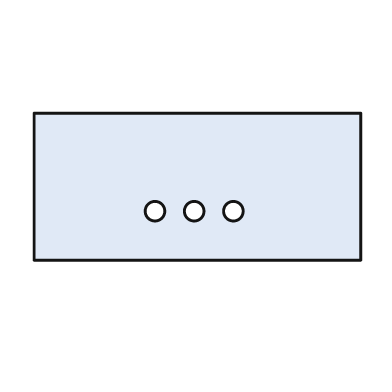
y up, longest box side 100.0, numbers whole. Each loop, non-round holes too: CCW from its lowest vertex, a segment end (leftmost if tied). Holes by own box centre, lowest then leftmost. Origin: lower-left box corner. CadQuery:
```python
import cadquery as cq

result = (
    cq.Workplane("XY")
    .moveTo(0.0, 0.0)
    .lineTo(100.0, 0.0)
    .lineTo(100.0, 45.0)
    .lineTo(0.0, 45.0)
    .close()
    .moveTo(37.0, 15.0)
    .circle(3.0)
    .moveTo(49.0, 15.0)
    .circle(3.0)
    .moveTo(61.0, 15.0)
    .circle(3.0)
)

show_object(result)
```